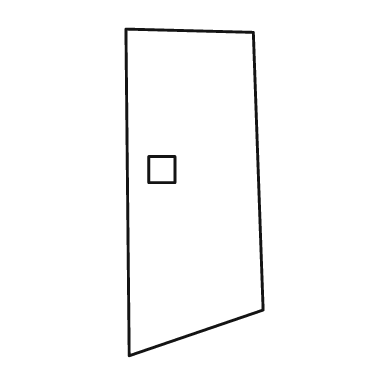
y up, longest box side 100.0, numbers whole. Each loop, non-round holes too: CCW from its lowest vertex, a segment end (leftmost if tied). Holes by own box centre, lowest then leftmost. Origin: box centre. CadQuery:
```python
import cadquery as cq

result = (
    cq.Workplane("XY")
    .moveTo(-20.0, -50.0)
    .lineTo(21.0, -36.0)
    .lineTo(18.0, 49.0)
    .lineTo(-21.0, 50.0)
    .close()
    .moveTo(-14.0, 3.0)
    .lineTo(-6.0, 3.0)
    .lineTo(-6.0, 11.0)
    .lineTo(-14.0, 11.0)
    .close()
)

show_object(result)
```